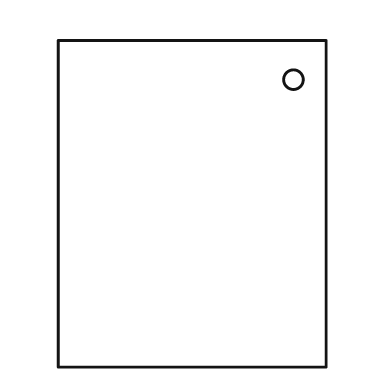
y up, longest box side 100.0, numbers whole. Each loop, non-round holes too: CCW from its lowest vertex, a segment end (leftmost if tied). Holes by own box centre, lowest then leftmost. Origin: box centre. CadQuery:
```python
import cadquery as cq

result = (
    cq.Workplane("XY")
    .moveTo(-41.0, -50.0)
    .lineTo(41.0, -50.0)
    .lineTo(41.0, 50.0)
    .lineTo(-41.0, 50.0)
    .close()
    .moveTo(31.0, 38.0)
    .circle(3.0)
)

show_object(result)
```